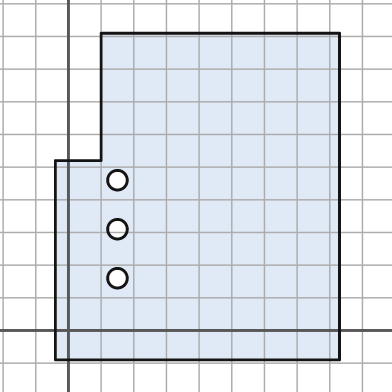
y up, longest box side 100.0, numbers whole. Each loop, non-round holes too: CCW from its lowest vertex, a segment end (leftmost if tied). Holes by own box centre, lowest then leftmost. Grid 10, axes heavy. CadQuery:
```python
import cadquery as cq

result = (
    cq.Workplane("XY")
    .moveTo(-4.0, -9.0)
    .lineTo(83.0, -9.0)
    .lineTo(83.0, 91.0)
    .lineTo(10.0, 91.0)
    .lineTo(10.0, 52.0)
    .lineTo(-4.0, 52.0)
    .close()
    .moveTo(15.0, 16.0)
    .circle(3.0)
    .moveTo(15.0, 31.0)
    .circle(3.0)
    .moveTo(15.0, 46.0)
    .circle(3.0)
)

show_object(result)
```